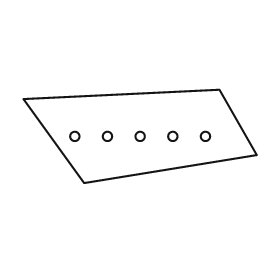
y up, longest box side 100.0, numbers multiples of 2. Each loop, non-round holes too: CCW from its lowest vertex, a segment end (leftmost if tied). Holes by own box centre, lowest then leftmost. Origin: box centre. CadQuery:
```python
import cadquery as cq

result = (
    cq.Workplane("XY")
    .moveTo(-24.0, -20.0)
    .lineTo(50.0, -8.0)
    .lineTo(34.0, 20.0)
    .lineTo(-50.0, 16.0)
    .close()
    .moveTo(-28.0, 0.0)
    .circle(2.0)
    .moveTo(-14.0, 0.0)
    .circle(2.0)
    .moveTo(0.0, 0.0)
    .circle(2.0)
    .moveTo(14.0, 0.0)
    .circle(2.0)
    .moveTo(28.0, 0.0)
    .circle(2.0)
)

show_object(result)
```